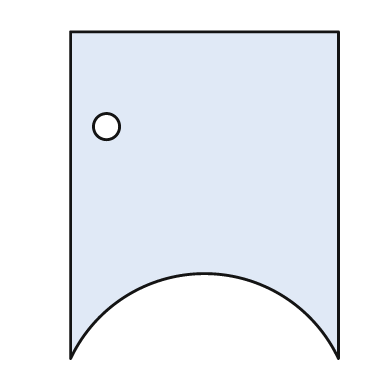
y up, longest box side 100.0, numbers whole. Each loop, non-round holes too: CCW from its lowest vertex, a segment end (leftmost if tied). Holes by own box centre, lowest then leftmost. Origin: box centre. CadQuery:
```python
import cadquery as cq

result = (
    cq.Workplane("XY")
    .moveTo(-41.0, -50.0)
    .threePointArc((0.0, -24.0), (41.0, -50.0))
    .lineTo(41.0, 50.0)
    .lineTo(-41.0, 50.0)
    .close()
    .moveTo(-30.0, 21.0)
    .circle(4.0)
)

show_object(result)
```